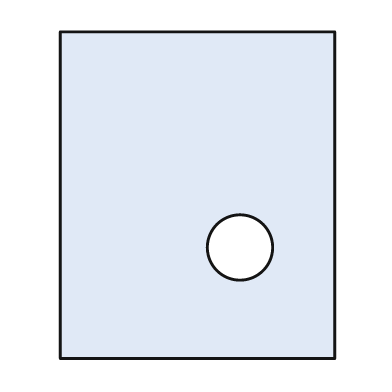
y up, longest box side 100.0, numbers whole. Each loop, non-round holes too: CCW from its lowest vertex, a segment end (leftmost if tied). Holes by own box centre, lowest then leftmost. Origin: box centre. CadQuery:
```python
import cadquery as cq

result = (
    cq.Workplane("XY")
    .moveTo(-42.0, -50.0)
    .lineTo(42.0, -50.0)
    .lineTo(42.0, 50.0)
    .lineTo(-42.0, 50.0)
    .close()
    .moveTo(13.0, -16.0)
    .circle(10.0)
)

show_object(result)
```